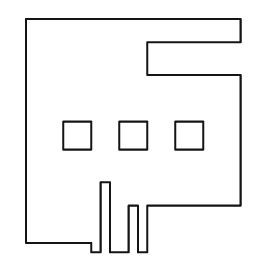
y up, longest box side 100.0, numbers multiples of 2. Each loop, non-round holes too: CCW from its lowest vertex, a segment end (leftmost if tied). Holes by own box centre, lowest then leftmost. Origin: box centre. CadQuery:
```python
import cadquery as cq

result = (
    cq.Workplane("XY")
    .moveTo(-18.0, -50.0)
    .lineTo(-14.0, -50.0)
    .lineTo(-14.0, -20.0)
    .lineTo(-10.0, -20.0)
    .lineTo(-10.0, -50.0)
    .lineTo(-2.0, -50.0)
    .lineTo(-2.0, -30.0)
    .lineTo(2.0, -30.0)
    .lineTo(2.0, -50.0)
    .lineTo(6.0, -50.0)
    .lineTo(6.0, -30.0)
    .lineTo(46.0, -30.0)
    .lineTo(46.0, 26.0)
    .lineTo(6.0, 26.0)
    .lineTo(6.0, 40.0)
    .lineTo(46.0, 40.0)
    .lineTo(46.0, 50.0)
    .lineTo(-46.0, 50.0)
    .lineTo(-46.0, -46.0)
    .lineTo(-18.0, -46.0)
    .close()
    .moveTo(-30.0, -6.0)
    .lineTo(-18.0, -6.0)
    .lineTo(-18.0, 6.0)
    .lineTo(-30.0, 6.0)
    .close()
    .moveTo(-6.0, -6.0)
    .lineTo(6.0, -6.0)
    .lineTo(6.0, 6.0)
    .lineTo(-6.0, 6.0)
    .close()
    .moveTo(18.0, -6.0)
    .lineTo(30.0, -6.0)
    .lineTo(30.0, 6.0)
    .lineTo(18.0, 6.0)
    .close()
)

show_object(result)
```